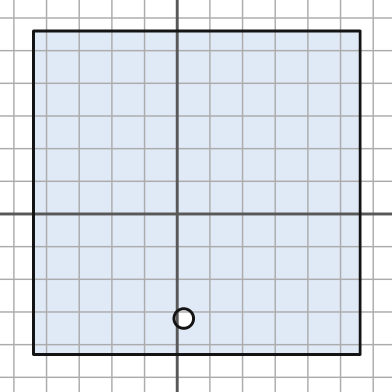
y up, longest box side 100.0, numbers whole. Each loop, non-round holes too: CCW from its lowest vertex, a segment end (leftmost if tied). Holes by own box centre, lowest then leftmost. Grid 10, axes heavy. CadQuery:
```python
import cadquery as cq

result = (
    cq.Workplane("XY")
    .moveTo(-44.0, -43.0)
    .lineTo(56.0, -43.0)
    .lineTo(56.0, 56.0)
    .lineTo(-44.0, 56.0)
    .close()
    .moveTo(2.0, -32.0)
    .circle(3.0)
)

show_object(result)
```